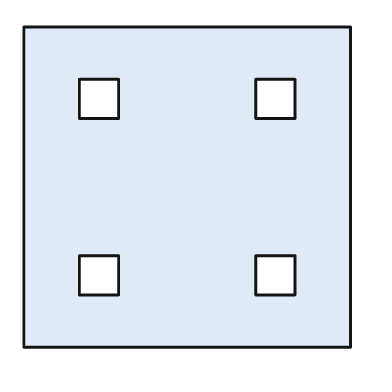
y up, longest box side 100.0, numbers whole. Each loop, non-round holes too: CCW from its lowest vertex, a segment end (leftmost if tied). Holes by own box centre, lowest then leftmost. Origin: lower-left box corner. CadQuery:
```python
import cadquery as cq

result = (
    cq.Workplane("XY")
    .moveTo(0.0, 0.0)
    .lineTo(100.0, 0.0)
    .lineTo(100.0, 98.0)
    .lineTo(0.0, 98.0)
    .close()
    .moveTo(17.0, 16.0)
    .lineTo(29.0, 16.0)
    .lineTo(29.0, 28.0)
    .lineTo(17.0, 28.0)
    .close()
    .moveTo(71.0, 16.0)
    .lineTo(83.0, 16.0)
    .lineTo(83.0, 28.0)
    .lineTo(71.0, 28.0)
    .close()
    .moveTo(17.0, 70.0)
    .lineTo(29.0, 70.0)
    .lineTo(29.0, 82.0)
    .lineTo(17.0, 82.0)
    .close()
    .moveTo(71.0, 70.0)
    .lineTo(83.0, 70.0)
    .lineTo(83.0, 82.0)
    .lineTo(71.0, 82.0)
    .close()
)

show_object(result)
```